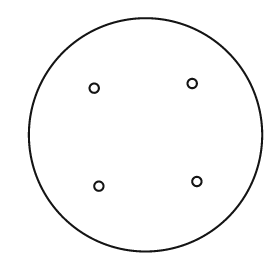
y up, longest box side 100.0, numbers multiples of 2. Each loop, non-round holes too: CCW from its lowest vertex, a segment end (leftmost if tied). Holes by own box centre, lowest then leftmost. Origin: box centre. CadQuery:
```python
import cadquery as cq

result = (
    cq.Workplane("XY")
    .moveTo(0.0, 0.0)
    .circle(50.0)
    .moveTo(-20.0, -22.0)
    .circle(2.0)
    .moveTo(22.0, -20.0)
    .circle(2.0)
    .moveTo(-22.0, 20.0)
    .circle(2.0)
    .moveTo(20.0, 22.0)
    .circle(2.0)
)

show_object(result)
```